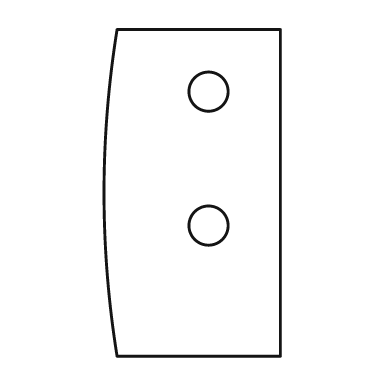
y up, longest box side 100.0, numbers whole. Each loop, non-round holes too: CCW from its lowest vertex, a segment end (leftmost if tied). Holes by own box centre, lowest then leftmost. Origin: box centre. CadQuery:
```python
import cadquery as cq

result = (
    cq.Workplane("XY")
    .moveTo(-23.0, -50.0)
    .lineTo(27.0, -50.0)
    .lineTo(27.0, 50.0)
    .lineTo(-23.0, 50.0)
    .threePointArc((-27.0, 0.0), (-23.0, -50.0))
    .close()
    .moveTo(5.0, -10.0)
    .circle(6.0)
    .moveTo(5.0, 31.0)
    .circle(6.0)
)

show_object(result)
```